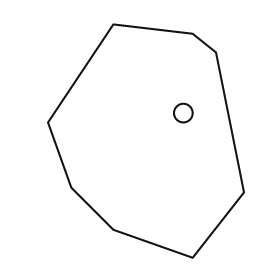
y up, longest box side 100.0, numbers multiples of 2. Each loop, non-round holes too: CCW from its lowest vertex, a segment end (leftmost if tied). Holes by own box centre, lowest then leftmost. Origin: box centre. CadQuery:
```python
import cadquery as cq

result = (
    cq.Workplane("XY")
    .moveTo(20.0, -50.0)
    .lineTo(42.0, -22.0)
    .lineTo(30.0, 38.0)
    .lineTo(20.0, 46.0)
    .lineTo(-14.0, 50.0)
    .lineTo(-42.0, 8.0)
    .lineTo(-32.0, -20.0)
    .lineTo(-14.0, -38.0)
    .close()
    .moveTo(16.0, 12.0)
    .circle(4.0)
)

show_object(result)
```